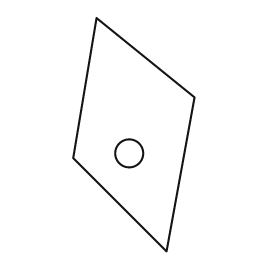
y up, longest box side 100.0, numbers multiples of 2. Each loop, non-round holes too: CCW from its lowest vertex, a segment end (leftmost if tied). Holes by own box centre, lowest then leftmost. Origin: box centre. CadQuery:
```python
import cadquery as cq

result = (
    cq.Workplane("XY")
    .moveTo(14.0, -50.0)
    .lineTo(26.0, 16.0)
    .lineTo(-16.0, 50.0)
    .lineTo(-26.0, -10.0)
    .close()
    .moveTo(-2.0, -8.0)
    .circle(6.0)
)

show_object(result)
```